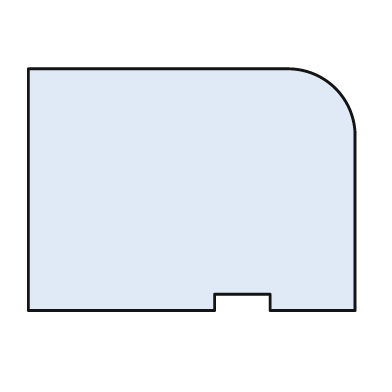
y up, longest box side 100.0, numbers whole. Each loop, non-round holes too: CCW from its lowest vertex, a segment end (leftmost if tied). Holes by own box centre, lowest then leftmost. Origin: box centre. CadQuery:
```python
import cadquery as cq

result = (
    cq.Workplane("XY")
    .moveTo(-50.0, -37.0)
    .lineTo(7.0, -37.0)
    .lineTo(7.0, -32.0)
    .lineTo(24.0, -32.0)
    .lineTo(24.0, -37.0)
    .lineTo(50.0, -37.0)
    .lineTo(50.0, 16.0)
    .threePointArc((44.0, 31.0), (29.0, 37.0))
    .lineTo(-50.0, 37.0)
    .close()
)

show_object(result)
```